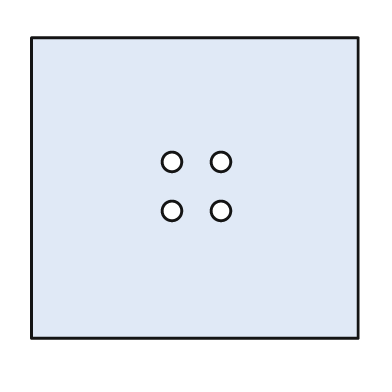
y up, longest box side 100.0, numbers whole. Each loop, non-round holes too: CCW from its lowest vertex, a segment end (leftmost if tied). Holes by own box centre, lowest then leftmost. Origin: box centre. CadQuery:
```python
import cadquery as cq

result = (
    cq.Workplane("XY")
    .moveTo(-50.0, -46.0)
    .lineTo(50.0, -46.0)
    .lineTo(50.0, 46.0)
    .lineTo(-50.0, 46.0)
    .close()
    .moveTo(-7.0, -7.0)
    .circle(3.0)
    .moveTo(8.0, -7.0)
    .circle(3.0)
    .moveTo(-7.0, 8.0)
    .circle(3.0)
    .moveTo(8.0, 8.0)
    .circle(3.0)
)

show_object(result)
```